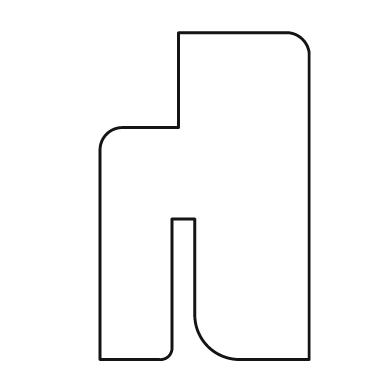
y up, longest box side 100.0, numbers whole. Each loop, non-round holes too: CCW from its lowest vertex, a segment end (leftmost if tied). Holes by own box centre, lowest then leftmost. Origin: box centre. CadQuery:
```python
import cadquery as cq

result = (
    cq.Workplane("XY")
    .moveTo(-32.0, -50.0)
    .lineTo(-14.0, -50.0)
    .threePointArc((-11.0, -49.0), (-10.0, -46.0))
    .lineTo(-10.0, -7.0)
    .lineTo(-3.0, -7.0)
    .lineTo(-3.0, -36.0)
    .threePointArc((1.0, -46.0), (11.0, -50.0))
    .lineTo(32.0, -50.0)
    .lineTo(32.0, 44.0)
    .threePointArc((30.0, 48.0), (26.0, 50.0))
    .lineTo(-8.0, 50.0)
    .lineTo(-8.0, 21.0)
    .lineTo(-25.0, 21.0)
    .threePointArc((-30.0, 19.0), (-32.0, 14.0))
    .close()
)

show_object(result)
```